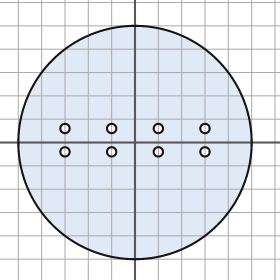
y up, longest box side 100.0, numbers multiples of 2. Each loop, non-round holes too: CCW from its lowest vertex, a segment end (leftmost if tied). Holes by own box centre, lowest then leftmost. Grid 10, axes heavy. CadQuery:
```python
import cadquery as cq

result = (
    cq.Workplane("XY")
    .moveTo(0.0, 0.0)
    .circle(50.0)
    .moveTo(-30.0, -4.0)
    .circle(2.0)
    .moveTo(-10.0, -4.0)
    .circle(2.0)
    .moveTo(10.0, -4.0)
    .circle(2.0)
    .moveTo(30.0, -4.0)
    .circle(2.0)
    .moveTo(-30.0, 6.0)
    .circle(2.0)
    .moveTo(-10.0, 6.0)
    .circle(2.0)
    .moveTo(10.0, 6.0)
    .circle(2.0)
    .moveTo(30.0, 6.0)
    .circle(2.0)
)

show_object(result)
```